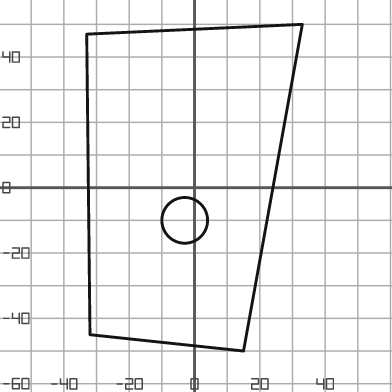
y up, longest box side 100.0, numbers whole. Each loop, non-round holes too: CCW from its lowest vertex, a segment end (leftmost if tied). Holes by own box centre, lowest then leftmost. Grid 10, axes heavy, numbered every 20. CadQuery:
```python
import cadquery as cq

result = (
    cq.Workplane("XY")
    .moveTo(15.0, -50.0)
    .lineTo(33.0, 50.0)
    .lineTo(-33.0, 47.0)
    .lineTo(-32.0, -45.0)
    .close()
    .moveTo(-3.0, -10.0)
    .circle(7.0)
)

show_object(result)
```